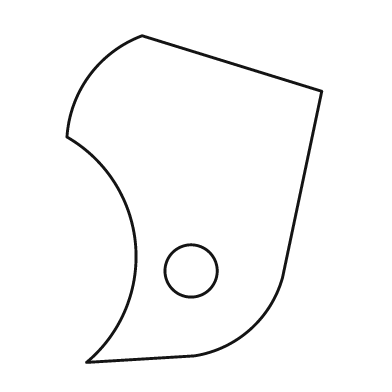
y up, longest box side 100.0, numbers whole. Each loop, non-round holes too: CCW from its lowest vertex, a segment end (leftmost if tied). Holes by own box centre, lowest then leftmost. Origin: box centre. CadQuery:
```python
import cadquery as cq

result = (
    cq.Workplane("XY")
    .moveTo(-33.0, -50.0)
    .lineTo(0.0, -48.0)
    .threePointArc((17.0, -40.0), (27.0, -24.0))
    .lineTo(39.0, 33.0)
    .lineTo(-16.0, 50.0)
    .threePointArc((-32.0, 38.0), (-39.0, 19.0))
    .threePointArc((-18.0, -14.0), (-33.0, -50.0))
    .close()
    .moveTo(-1.0, -22.0)
    .circle(8.0)
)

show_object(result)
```